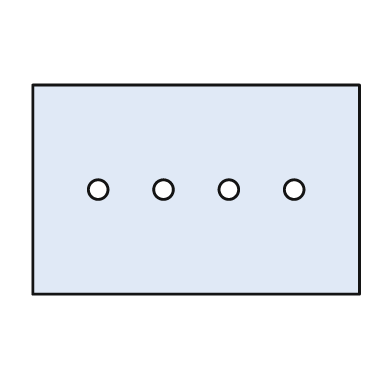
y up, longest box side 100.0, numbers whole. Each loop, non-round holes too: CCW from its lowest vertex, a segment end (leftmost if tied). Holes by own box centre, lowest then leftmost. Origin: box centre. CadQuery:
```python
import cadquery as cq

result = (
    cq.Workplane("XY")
    .moveTo(-50.0, -32.0)
    .lineTo(50.0, -32.0)
    .lineTo(50.0, 32.0)
    .lineTo(-50.0, 32.0)
    .close()
    .moveTo(-30.0, 0.0)
    .circle(3.0)
    .moveTo(-10.0, 0.0)
    .circle(3.0)
    .moveTo(10.0, 0.0)
    .circle(3.0)
    .moveTo(30.0, 0.0)
    .circle(3.0)
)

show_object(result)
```